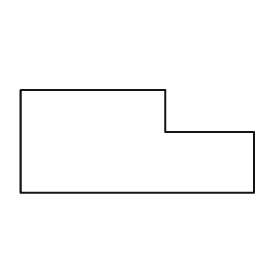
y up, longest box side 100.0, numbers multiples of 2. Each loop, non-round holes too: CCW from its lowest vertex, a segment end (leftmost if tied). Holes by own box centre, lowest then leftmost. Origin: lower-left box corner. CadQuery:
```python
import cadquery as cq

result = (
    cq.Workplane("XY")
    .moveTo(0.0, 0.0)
    .lineTo(100.0, 0.0)
    .lineTo(100.0, 26.0)
    .lineTo(62.0, 26.0)
    .lineTo(62.0, 44.0)
    .lineTo(0.0, 44.0)
    .close()
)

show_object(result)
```